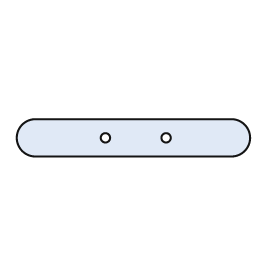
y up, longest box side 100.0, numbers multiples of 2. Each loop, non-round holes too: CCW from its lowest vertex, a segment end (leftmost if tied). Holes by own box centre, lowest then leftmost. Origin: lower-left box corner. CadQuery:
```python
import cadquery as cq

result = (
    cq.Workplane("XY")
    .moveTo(8.0, 0.0)
    .lineTo(92.0, 0.0)
    .threePointArc((100.0, 8.0), (92.0, 16.0))
    .lineTo(8.0, 16.0)
    .threePointArc((0.0, 8.0), (8.0, 0.0))
    .close()
    .moveTo(38.0, 8.0)
    .circle(2.0)
    .moveTo(64.0, 8.0)
    .circle(2.0)
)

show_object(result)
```